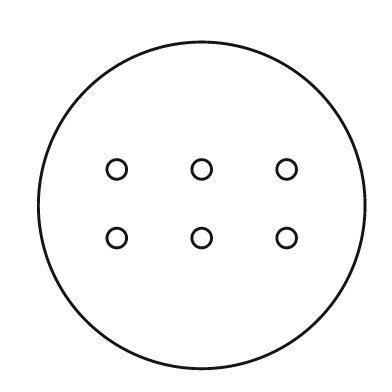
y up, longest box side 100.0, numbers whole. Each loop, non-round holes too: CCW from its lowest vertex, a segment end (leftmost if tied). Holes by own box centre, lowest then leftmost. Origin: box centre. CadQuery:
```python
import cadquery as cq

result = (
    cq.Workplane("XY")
    .moveTo(0.0, 0.0)
    .circle(50.0)
    .moveTo(-26.0, -10.0)
    .circle(3.0)
    .moveTo(0.0, -10.0)
    .circle(3.0)
    .moveTo(26.0, -10.0)
    .circle(3.0)
    .moveTo(-26.0, 11.0)
    .circle(3.0)
    .moveTo(0.0, 11.0)
    .circle(3.0)
    .moveTo(26.0, 11.0)
    .circle(3.0)
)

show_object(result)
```